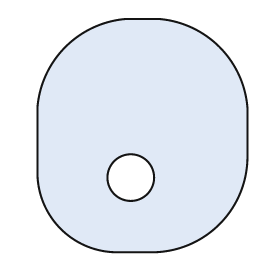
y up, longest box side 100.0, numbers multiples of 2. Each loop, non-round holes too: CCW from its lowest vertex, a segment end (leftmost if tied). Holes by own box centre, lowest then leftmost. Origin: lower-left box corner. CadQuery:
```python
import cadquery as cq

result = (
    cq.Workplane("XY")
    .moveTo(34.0, 0.0)
    .lineTo(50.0, 0.0)
    .threePointArc((78.0, 12.0), (90.0, 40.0))
    .lineTo(90.0, 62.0)
    .threePointArc((78.0, 88.0), (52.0, 100.0))
    .lineTo(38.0, 100.0)
    .threePointArc((12.0, 88.0), (0.0, 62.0))
    .lineTo(0.0, 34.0)
    .threePointArc((10.0, 10.0), (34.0, 0.0))
    .close()
    .moveTo(40.0, 32.0)
    .circle(10.0)
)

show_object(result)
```